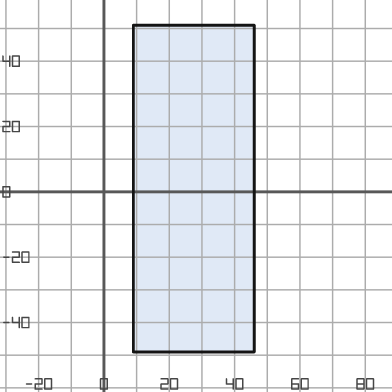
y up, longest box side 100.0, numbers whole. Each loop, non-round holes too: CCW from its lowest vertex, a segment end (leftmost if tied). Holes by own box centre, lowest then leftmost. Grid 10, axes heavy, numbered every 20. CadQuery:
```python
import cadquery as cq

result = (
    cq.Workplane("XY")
    .moveTo(9.0, -49.0)
    .lineTo(46.0, -49.0)
    .lineTo(46.0, 51.0)
    .lineTo(9.0, 51.0)
    .close()
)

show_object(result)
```